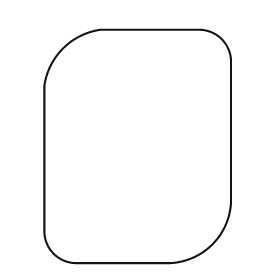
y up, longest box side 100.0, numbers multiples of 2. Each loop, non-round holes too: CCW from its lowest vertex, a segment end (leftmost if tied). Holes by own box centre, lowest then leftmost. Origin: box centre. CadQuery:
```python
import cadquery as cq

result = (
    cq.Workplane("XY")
    .moveTo(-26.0, -50.0)
    .lineTo(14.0, -50.0)
    .threePointArc((32.0, -42.0), (40.0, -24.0))
    .lineTo(40.0, 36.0)
    .threePointArc((36.0, 46.0), (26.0, 50.0))
    .lineTo(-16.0, 50.0)
    .threePointArc((-32.0, 42.0), (-40.0, 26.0))
    .lineTo(-40.0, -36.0)
    .threePointArc((-36.0, -46.0), (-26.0, -50.0))
    .close()
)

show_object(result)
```